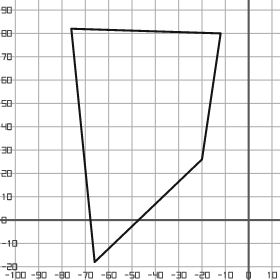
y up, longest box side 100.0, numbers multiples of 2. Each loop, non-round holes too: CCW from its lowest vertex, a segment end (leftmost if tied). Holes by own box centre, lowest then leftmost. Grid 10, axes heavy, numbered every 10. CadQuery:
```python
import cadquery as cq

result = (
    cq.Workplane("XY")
    .moveTo(-66.0, -18.0)
    .lineTo(-20.0, 26.0)
    .lineTo(-12.0, 80.0)
    .lineTo(-76.0, 82.0)
    .close()
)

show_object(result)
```